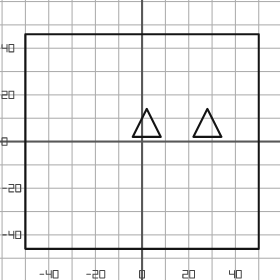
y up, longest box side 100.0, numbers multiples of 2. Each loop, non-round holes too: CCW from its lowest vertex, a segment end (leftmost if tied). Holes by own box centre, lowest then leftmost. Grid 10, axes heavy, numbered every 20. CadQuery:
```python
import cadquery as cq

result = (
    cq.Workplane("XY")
    .moveTo(-50.0, -46.0)
    .lineTo(50.0, -46.0)
    .lineTo(50.0, 46.0)
    .lineTo(-50.0, 46.0)
    .close()
    .moveTo(-4.0, 2.0)
    .lineTo(8.0, 2.0)
    .lineTo(2.0, 14.0)
    .close()
    .moveTo(22.0, 2.0)
    .lineTo(34.0, 2.0)
    .lineTo(28.0, 14.0)
    .close()
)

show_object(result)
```